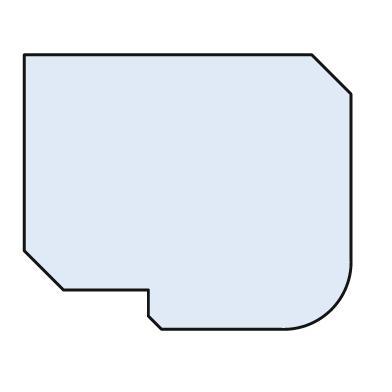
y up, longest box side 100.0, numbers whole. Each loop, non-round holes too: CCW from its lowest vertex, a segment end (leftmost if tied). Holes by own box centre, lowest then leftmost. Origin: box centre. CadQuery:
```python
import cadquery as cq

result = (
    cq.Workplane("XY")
    .moveTo(-8.0, -42.0)
    .lineTo(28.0, -42.0)
    .threePointArc((44.0, -36.0), (50.0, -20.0))
    .lineTo(50.0, 30.0)
    .lineTo(38.0, 42.0)
    .lineTo(-50.0, 42.0)
    .lineTo(-50.0, -18.0)
    .lineTo(-38.0, -30.0)
    .lineTo(-12.0, -30.0)
    .lineTo(-12.0, -38.0)
    .close()
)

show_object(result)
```